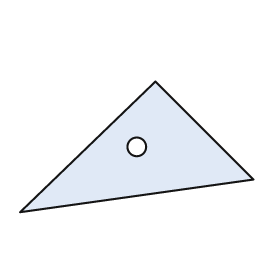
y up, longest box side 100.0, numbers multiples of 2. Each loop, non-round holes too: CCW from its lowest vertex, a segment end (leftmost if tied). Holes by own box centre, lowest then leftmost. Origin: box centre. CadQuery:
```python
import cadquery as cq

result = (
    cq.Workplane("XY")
    .moveTo(-50.0, -28.0)
    .lineTo(50.0, -14.0)
    .lineTo(8.0, 28.0)
    .close()
    .moveTo(0.0, 0.0)
    .circle(4.0)
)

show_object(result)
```